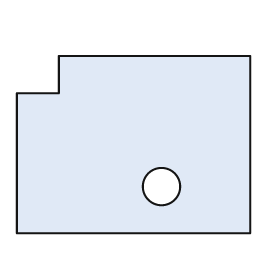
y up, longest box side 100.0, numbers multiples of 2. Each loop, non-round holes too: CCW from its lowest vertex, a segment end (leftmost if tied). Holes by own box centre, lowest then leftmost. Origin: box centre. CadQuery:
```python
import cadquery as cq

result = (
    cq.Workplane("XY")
    .moveTo(-50.0, -38.0)
    .lineTo(50.0, -38.0)
    .lineTo(50.0, 38.0)
    .lineTo(-32.0, 38.0)
    .lineTo(-32.0, 22.0)
    .lineTo(-50.0, 22.0)
    .close()
    .moveTo(12.0, -18.0)
    .circle(8.0)
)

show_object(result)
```